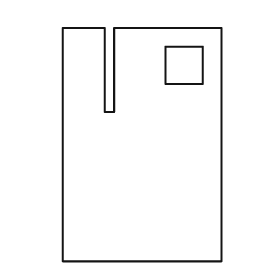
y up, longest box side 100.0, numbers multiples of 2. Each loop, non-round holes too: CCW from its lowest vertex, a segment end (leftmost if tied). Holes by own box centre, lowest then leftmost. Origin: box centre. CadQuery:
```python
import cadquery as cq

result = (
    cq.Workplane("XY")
    .moveTo(-34.0, -50.0)
    .lineTo(34.0, -50.0)
    .lineTo(34.0, 50.0)
    .lineTo(-12.0, 50.0)
    .lineTo(-12.0, 14.0)
    .lineTo(-16.0, 14.0)
    .lineTo(-16.0, 50.0)
    .lineTo(-34.0, 50.0)
    .close()
    .moveTo(10.0, 26.0)
    .lineTo(26.0, 26.0)
    .lineTo(26.0, 42.0)
    .lineTo(10.0, 42.0)
    .close()
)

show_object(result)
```